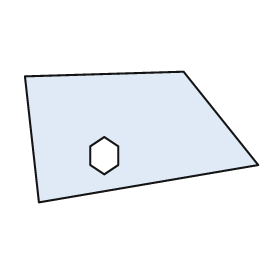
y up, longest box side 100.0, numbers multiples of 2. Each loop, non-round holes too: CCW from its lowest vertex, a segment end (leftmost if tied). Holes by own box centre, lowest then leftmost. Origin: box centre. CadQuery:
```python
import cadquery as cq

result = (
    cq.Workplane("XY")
    .moveTo(-44.0, -28.0)
    .lineTo(50.0, -12.0)
    .lineTo(18.0, 28.0)
    .lineTo(-50.0, 26.0)
    .close()
    .moveTo(-16.0, -16.0)
    .lineTo(-10.0, -12.0)
    .lineTo(-10.0, -4.0)
    .lineTo(-16.0, 0.0)
    .lineTo(-22.0, -4.0)
    .lineTo(-22.0, -12.0)
    .close()
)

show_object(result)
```